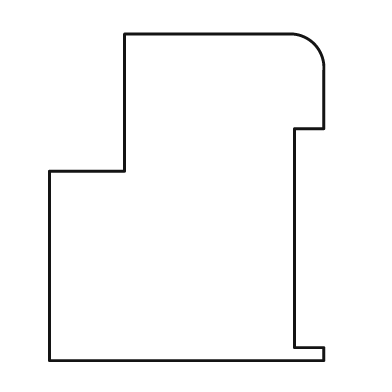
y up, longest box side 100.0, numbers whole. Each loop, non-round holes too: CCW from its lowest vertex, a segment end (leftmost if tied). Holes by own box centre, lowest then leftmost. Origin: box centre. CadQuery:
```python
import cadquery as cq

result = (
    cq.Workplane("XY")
    .moveTo(-42.0, -50.0)
    .lineTo(42.0, -50.0)
    .lineTo(42.0, -46.0)
    .lineTo(33.0, -46.0)
    .lineTo(33.0, 21.0)
    .lineTo(42.0, 21.0)
    .lineTo(42.0, 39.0)
    .threePointArc((39.0, 47.0), (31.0, 50.0))
    .lineTo(-19.0, 50.0)
    .lineTo(-19.0, 8.0)
    .lineTo(-42.0, 8.0)
    .close()
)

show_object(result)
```